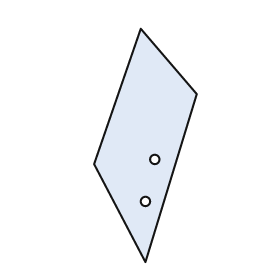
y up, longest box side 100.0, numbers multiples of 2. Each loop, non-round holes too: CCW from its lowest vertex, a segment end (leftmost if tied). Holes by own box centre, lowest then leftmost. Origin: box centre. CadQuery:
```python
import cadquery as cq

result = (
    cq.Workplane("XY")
    .moveTo(0.0, -50.0)
    .lineTo(22.0, 22.0)
    .lineTo(-2.0, 50.0)
    .lineTo(-22.0, -8.0)
    .close()
    .moveTo(0.0, -24.0)
    .circle(2.0)
    .moveTo(4.0, -6.0)
    .circle(2.0)
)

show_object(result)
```